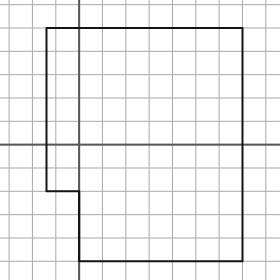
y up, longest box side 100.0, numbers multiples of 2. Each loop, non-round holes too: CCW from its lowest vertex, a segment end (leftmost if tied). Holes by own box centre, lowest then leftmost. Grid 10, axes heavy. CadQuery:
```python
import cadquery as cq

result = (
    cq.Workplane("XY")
    .moveTo(0.0, -50.0)
    .lineTo(70.0, -50.0)
    .lineTo(70.0, 50.0)
    .lineTo(-14.0, 50.0)
    .lineTo(-14.0, -20.0)
    .lineTo(0.0, -20.0)
    .close()
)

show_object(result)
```